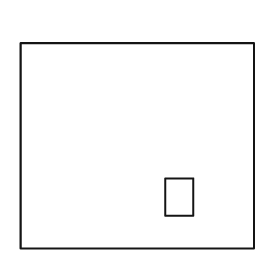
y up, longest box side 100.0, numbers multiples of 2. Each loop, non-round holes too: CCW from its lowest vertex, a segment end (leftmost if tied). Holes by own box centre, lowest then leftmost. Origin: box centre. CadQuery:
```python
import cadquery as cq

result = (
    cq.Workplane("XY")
    .moveTo(-50.0, -44.0)
    .lineTo(50.0, -44.0)
    .lineTo(50.0, 44.0)
    .lineTo(-50.0, 44.0)
    .close()
    .moveTo(12.0, -30.0)
    .lineTo(24.0, -30.0)
    .lineTo(24.0, -14.0)
    .lineTo(12.0, -14.0)
    .close()
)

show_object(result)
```